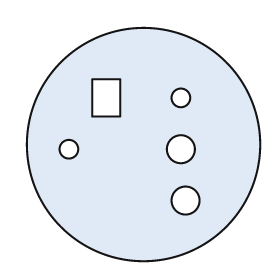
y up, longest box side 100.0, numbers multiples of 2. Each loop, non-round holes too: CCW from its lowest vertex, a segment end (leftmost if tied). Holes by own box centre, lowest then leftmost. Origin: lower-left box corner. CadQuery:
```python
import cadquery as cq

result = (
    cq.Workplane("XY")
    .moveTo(50.0, 50.0)
    .circle(50.0)
    .moveTo(68.0, 26.0)
    .circle(6.0)
    .moveTo(18.0, 48.0)
    .circle(4.0)
    .moveTo(66.0, 48.0)
    .circle(6.0)
    .moveTo(28.0, 62.0)
    .lineTo(40.0, 62.0)
    .lineTo(40.0, 78.0)
    .lineTo(28.0, 78.0)
    .close()
    .moveTo(66.0, 70.0)
    .circle(4.0)
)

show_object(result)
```